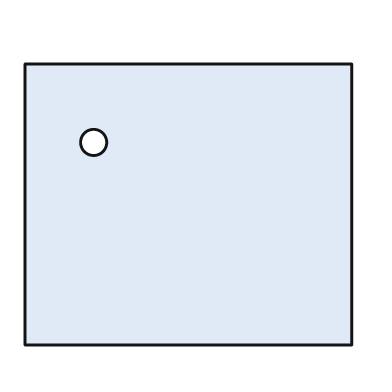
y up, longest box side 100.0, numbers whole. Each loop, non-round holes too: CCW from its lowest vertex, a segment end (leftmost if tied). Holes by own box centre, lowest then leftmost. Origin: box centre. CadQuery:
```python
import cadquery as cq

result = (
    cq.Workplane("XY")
    .moveTo(-50.0, -43.0)
    .lineTo(50.0, -43.0)
    .lineTo(50.0, 43.0)
    .lineTo(-50.0, 43.0)
    .close()
    .moveTo(-29.0, 19.0)
    .circle(4.0)
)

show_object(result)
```